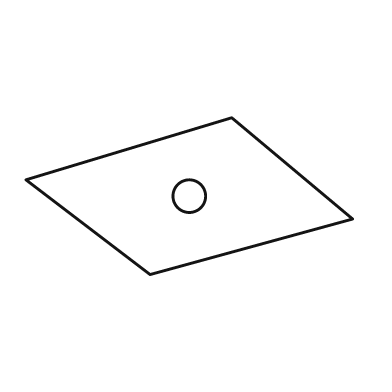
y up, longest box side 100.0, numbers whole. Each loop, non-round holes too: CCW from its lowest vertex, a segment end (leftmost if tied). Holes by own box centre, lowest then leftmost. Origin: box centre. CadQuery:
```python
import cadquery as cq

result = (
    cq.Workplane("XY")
    .moveTo(-12.0, -24.0)
    .lineTo(50.0, -7.0)
    .lineTo(13.0, 24.0)
    .lineTo(-50.0, 5.0)
    .close()
    .moveTo(0.0, 0.0)
    .circle(5.0)
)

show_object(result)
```